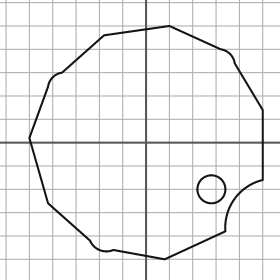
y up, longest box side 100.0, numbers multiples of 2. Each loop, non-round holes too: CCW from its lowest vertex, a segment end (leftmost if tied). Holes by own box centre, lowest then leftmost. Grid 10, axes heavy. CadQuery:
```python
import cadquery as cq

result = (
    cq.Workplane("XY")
    .moveTo(8.0, -50.0)
    .lineTo(34.0, -38.0)
    .threePointArc((38.0, -24.0), (50.0, -16.0))
    .lineTo(50.0, 14.0)
    .lineTo(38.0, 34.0)
    .threePointArc((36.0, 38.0), (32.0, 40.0))
    .lineTo(10.0, 50.0)
    .lineTo(-18.0, 46.0)
    .lineTo(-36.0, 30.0)
    .threePointArc((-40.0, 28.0), (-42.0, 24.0))
    .lineTo(-50.0, 2.0)
    .lineTo(-42.0, -26.0)
    .lineTo(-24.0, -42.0)
    .threePointArc((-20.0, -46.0), (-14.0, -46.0))
    .close()
    .moveTo(28.0, -20.0)
    .circle(6.0)
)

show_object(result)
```